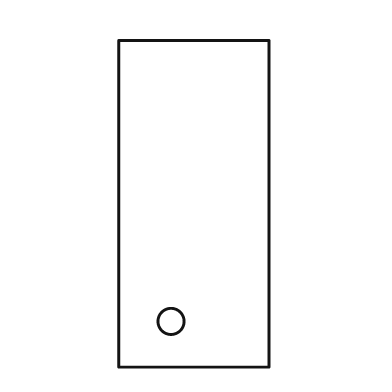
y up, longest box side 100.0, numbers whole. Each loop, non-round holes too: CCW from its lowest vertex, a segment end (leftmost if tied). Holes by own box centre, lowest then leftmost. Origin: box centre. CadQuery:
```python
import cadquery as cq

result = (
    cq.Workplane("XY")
    .moveTo(-23.0, -50.0)
    .lineTo(23.0, -50.0)
    .lineTo(23.0, 50.0)
    .lineTo(-23.0, 50.0)
    .close()
    .moveTo(-7.0, -36.0)
    .circle(4.0)
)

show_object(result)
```